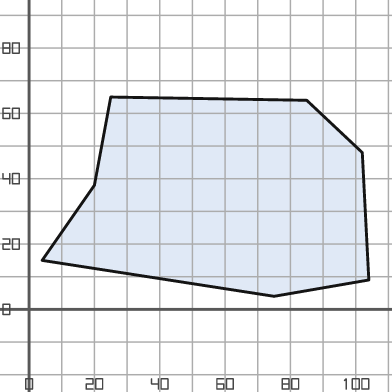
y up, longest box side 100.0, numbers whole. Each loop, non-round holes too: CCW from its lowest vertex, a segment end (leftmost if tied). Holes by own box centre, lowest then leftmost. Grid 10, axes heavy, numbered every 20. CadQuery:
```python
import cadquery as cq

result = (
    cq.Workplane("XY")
    .moveTo(75.0, 4.0)
    .lineTo(104.0, 9.0)
    .lineTo(102.0, 48.0)
    .lineTo(85.0, 64.0)
    .lineTo(25.0, 65.0)
    .lineTo(20.0, 38.0)
    .lineTo(4.0, 15.0)
    .close()
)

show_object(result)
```